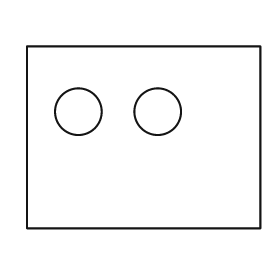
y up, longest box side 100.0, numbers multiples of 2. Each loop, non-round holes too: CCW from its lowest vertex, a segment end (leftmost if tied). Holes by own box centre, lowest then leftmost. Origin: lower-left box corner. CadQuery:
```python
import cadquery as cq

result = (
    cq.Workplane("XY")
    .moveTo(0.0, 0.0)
    .lineTo(100.0, 0.0)
    .lineTo(100.0, 78.0)
    .lineTo(0.0, 78.0)
    .close()
    .moveTo(22.0, 50.0)
    .circle(10.0)
    .moveTo(56.0, 50.0)
    .circle(10.0)
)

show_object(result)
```